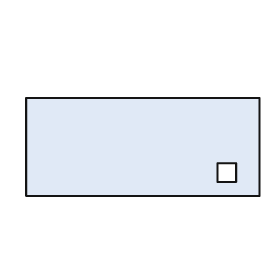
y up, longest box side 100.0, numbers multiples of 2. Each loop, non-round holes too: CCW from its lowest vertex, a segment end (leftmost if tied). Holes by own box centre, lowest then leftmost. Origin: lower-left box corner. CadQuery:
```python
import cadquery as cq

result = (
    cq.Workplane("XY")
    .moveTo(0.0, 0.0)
    .lineTo(100.0, 0.0)
    .lineTo(100.0, 42.0)
    .lineTo(0.0, 42.0)
    .close()
    .moveTo(82.0, 6.0)
    .lineTo(90.0, 6.0)
    .lineTo(90.0, 14.0)
    .lineTo(82.0, 14.0)
    .close()
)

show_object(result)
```